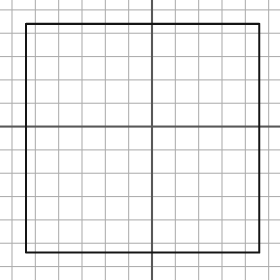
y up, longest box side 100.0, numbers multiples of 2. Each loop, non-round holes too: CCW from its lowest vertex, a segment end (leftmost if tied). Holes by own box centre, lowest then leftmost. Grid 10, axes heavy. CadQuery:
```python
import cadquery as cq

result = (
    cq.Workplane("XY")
    .moveTo(-54.0, -54.0)
    .lineTo(46.0, -54.0)
    .lineTo(46.0, 44.0)
    .lineTo(-54.0, 44.0)
    .close()
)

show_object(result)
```